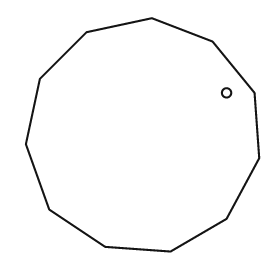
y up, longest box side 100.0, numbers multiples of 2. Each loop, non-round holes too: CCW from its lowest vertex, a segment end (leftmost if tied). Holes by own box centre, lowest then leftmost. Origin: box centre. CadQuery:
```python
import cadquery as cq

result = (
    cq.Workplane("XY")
    .moveTo(12.0, -50.0)
    .lineTo(36.0, -36.0)
    .lineTo(50.0, -10.0)
    .lineTo(48.0, 18.0)
    .lineTo(30.0, 40.0)
    .lineTo(4.0, 50.0)
    .lineTo(-24.0, 44.0)
    .lineTo(-44.0, 24.0)
    .lineTo(-50.0, -4.0)
    .lineTo(-40.0, -32.0)
    .lineTo(-16.0, -48.0)
    .close()
    .moveTo(36.0, 18.0)
    .circle(2.0)
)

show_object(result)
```